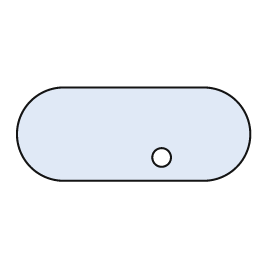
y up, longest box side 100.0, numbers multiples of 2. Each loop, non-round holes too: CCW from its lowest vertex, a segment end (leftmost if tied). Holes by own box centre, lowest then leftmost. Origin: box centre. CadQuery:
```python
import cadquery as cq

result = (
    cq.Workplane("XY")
    .moveTo(-30.0, -20.0)
    .lineTo(30.0, -20.0)
    .threePointArc((50.0, 0.0), (30.0, 20.0))
    .lineTo(-30.0, 20.0)
    .threePointArc((-50.0, 0.0), (-30.0, -20.0))
    .close()
    .moveTo(12.0, -10.0)
    .circle(4.0)
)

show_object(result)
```